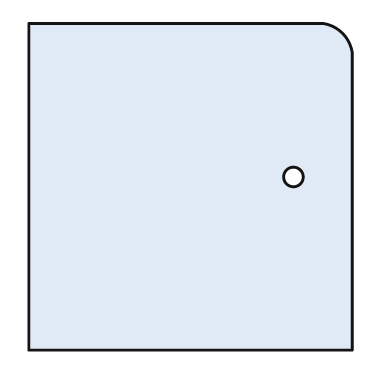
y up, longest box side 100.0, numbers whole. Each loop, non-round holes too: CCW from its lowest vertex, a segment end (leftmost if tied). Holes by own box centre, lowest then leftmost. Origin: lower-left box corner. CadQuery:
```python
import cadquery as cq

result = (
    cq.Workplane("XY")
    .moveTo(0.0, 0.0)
    .lineTo(99.0, 0.0)
    .lineTo(99.0, 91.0)
    .threePointArc((96.0, 97.0), (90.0, 100.0))
    .lineTo(0.0, 100.0)
    .close()
    .moveTo(81.0, 53.0)
    .circle(3.0)
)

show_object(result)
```